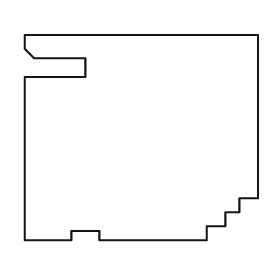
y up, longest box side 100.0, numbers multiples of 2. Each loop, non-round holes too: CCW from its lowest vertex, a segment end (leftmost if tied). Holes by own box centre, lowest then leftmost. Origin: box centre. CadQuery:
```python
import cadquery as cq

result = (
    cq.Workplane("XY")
    .moveTo(-50.0, -44.0)
    .lineTo(-30.0, -44.0)
    .lineTo(-30.0, -40.0)
    .lineTo(-18.0, -40.0)
    .lineTo(-18.0, -44.0)
    .lineTo(28.0, -44.0)
    .lineTo(28.0, -38.0)
    .lineTo(36.0, -38.0)
    .lineTo(36.0, -32.0)
    .lineTo(42.0, -32.0)
    .lineTo(42.0, -26.0)
    .lineTo(50.0, -26.0)
    .lineTo(50.0, 44.0)
    .lineTo(-50.0, 44.0)
    .lineTo(-50.0, 38.0)
    .lineTo(-46.0, 34.0)
    .lineTo(-24.0, 34.0)
    .lineTo(-24.0, 26.0)
    .lineTo(-50.0, 26.0)
    .close()
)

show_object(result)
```